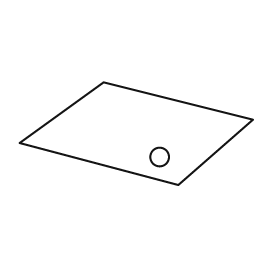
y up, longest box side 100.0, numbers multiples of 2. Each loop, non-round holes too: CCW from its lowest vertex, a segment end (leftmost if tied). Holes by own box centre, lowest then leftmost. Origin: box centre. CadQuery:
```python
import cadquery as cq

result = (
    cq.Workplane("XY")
    .moveTo(18.0, -22.0)
    .lineTo(50.0, 6.0)
    .lineTo(-14.0, 22.0)
    .lineTo(-50.0, -4.0)
    .close()
    .moveTo(10.0, -10.0)
    .circle(4.0)
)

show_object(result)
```